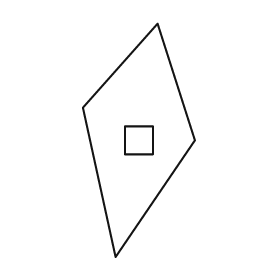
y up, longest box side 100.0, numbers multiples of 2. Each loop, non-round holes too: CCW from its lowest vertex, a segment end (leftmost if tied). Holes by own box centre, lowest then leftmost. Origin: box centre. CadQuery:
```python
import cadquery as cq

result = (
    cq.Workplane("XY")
    .moveTo(-10.0, -50.0)
    .lineTo(24.0, 0.0)
    .lineTo(8.0, 50.0)
    .lineTo(-24.0, 14.0)
    .close()
    .moveTo(-6.0, -6.0)
    .lineTo(6.0, -6.0)
    .lineTo(6.0, 6.0)
    .lineTo(-6.0, 6.0)
    .close()
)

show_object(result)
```